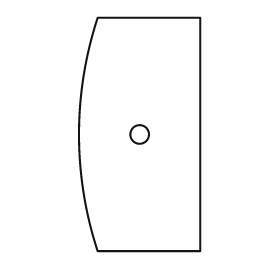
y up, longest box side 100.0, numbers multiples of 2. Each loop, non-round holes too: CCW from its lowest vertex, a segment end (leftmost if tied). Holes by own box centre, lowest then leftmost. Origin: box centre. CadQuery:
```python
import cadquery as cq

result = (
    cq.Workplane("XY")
    .moveTo(-18.0, -50.0)
    .lineTo(26.0, -50.0)
    .lineTo(26.0, 50.0)
    .lineTo(-18.0, 50.0)
    .threePointArc((-26.0, 0.0), (-18.0, -50.0))
    .close()
    .moveTo(0.0, 0.0)
    .circle(4.0)
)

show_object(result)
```